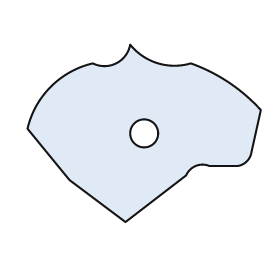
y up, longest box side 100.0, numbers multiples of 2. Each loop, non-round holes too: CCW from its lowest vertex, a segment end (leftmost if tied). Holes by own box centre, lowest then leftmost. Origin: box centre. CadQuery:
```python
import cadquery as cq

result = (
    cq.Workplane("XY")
    .moveTo(-8.0, -38.0)
    .lineTo(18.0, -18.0)
    .threePointArc((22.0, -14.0), (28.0, -14.0))
    .lineTo(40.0, -14.0)
    .threePointArc((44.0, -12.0), (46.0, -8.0))
    .lineTo(50.0, 10.0)
    .threePointArc((36.0, 22.0), (20.0, 30.0))
    .threePointArc((6.0, 30.0), (-6.0, 38.0))
    .threePointArc((-12.0, 30.0), (-22.0, 30.0))
    .threePointArc((-40.0, 20.0), (-50.0, 2.0))
    .lineTo(-32.0, -20.0)
    .close()
    .moveTo(0.0, 0.0)
    .circle(6.0)
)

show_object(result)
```